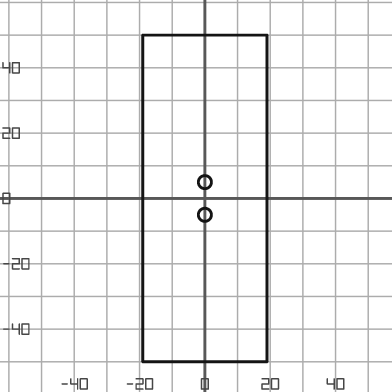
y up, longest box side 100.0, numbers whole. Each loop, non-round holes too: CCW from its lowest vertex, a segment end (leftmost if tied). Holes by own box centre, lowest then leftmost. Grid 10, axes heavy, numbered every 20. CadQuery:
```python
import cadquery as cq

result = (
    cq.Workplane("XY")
    .moveTo(-19.0, -50.0)
    .lineTo(19.0, -50.0)
    .lineTo(19.0, 50.0)
    .lineTo(-19.0, 50.0)
    .close()
    .moveTo(0.0, -5.0)
    .circle(2.0)
    .moveTo(0.0, 5.0)
    .circle(2.0)
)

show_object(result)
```